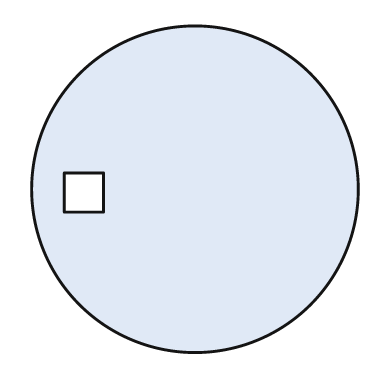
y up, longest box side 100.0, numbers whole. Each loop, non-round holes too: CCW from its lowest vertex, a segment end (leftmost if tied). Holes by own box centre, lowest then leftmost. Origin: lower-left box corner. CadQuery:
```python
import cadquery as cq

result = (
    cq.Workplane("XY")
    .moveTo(50.0, 50.0)
    .circle(50.0)
    .moveTo(10.0, 43.0)
    .lineTo(22.0, 43.0)
    .lineTo(22.0, 55.0)
    .lineTo(10.0, 55.0)
    .close()
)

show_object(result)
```